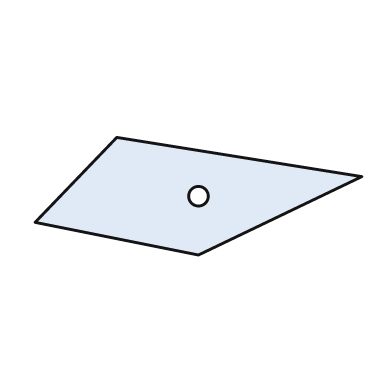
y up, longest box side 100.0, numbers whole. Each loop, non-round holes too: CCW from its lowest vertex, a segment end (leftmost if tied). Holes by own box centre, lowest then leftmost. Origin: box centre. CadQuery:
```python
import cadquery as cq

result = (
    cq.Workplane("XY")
    .moveTo(0.0, -18.0)
    .lineTo(50.0, 6.0)
    .lineTo(-25.0, 18.0)
    .lineTo(-50.0, -8.0)
    .close()
    .moveTo(0.0, 0.0)
    .circle(3.0)
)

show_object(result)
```